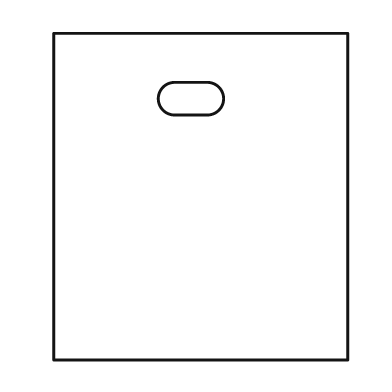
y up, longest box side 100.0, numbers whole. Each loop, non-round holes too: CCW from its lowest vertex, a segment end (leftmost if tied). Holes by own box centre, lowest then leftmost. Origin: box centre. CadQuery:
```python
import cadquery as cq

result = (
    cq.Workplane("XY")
    .moveTo(-45.0, -50.0)
    .lineTo(45.0, -50.0)
    .lineTo(45.0, 50.0)
    .lineTo(-45.0, 50.0)
    .close()
    .moveTo(-8.0, 25.0)
    .lineTo(2.0, 25.0)
    .threePointArc((7.0, 30.0), (2.0, 35.0))
    .lineTo(-8.0, 35.0)
    .threePointArc((-13.0, 30.0), (-8.0, 25.0))
    .close()
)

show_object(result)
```